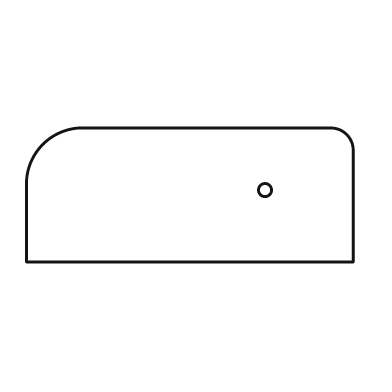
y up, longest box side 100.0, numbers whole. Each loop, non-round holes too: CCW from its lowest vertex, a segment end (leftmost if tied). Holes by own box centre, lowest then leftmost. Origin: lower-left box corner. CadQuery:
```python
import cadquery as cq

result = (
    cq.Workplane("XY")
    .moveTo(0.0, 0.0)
    .lineTo(100.0, 0.0)
    .lineTo(100.0, 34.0)
    .threePointArc((98.0, 39.0), (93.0, 41.0))
    .lineTo(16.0, 41.0)
    .threePointArc((5.0, 36.0), (0.0, 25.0))
    .close()
    .moveTo(73.0, 22.0)
    .circle(2.0)
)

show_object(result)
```